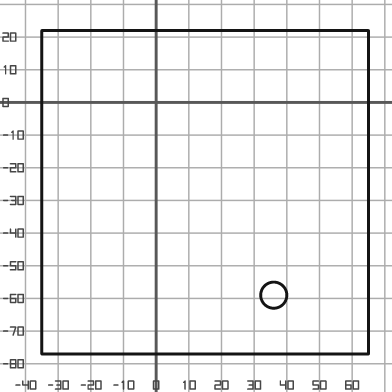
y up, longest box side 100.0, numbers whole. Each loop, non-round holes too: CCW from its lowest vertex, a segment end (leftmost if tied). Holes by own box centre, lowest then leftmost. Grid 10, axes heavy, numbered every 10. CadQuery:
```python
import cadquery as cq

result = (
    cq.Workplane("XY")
    .moveTo(-35.0, -77.0)
    .lineTo(65.0, -77.0)
    .lineTo(65.0, 22.0)
    .lineTo(-35.0, 22.0)
    .close()
    .moveTo(36.0, -59.0)
    .circle(4.0)
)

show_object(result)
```